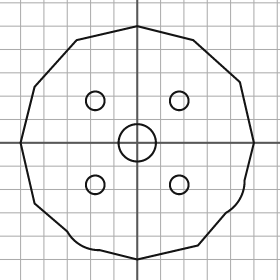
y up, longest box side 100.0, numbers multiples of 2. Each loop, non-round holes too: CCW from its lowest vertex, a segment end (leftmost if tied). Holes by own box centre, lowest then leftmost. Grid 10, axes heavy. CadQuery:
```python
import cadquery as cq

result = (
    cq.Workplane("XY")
    .moveTo(0.0, -50.0)
    .lineTo(26.0, -44.0)
    .lineTo(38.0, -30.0)
    .threePointArc((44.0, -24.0), (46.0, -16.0))
    .lineTo(50.0, 0.0)
    .lineTo(44.0, 26.0)
    .lineTo(24.0, 44.0)
    .lineTo(0.0, 50.0)
    .lineTo(-26.0, 44.0)
    .lineTo(-44.0, 24.0)
    .lineTo(-50.0, 0.0)
    .lineTo(-44.0, -26.0)
    .lineTo(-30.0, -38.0)
    .threePointArc((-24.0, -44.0), (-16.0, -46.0))
    .close()
    .moveTo(-18.0, -18.0)
    .circle(4.0)
    .moveTo(18.0, -18.0)
    .circle(4.0)
    .moveTo(0.0, 0.0)
    .circle(8.0)
    .moveTo(-18.0, 18.0)
    .circle(4.0)
    .moveTo(18.0, 18.0)
    .circle(4.0)
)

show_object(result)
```